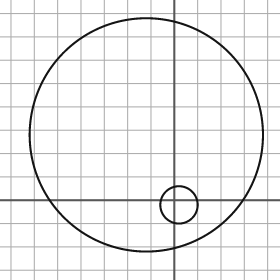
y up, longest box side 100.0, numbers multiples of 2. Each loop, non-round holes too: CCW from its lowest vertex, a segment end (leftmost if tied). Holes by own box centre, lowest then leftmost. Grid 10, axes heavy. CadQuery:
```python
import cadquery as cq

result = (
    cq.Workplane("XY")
    .moveTo(-12.0, 28.0)
    .circle(50.0)
    .moveTo(2.0, -2.0)
    .circle(8.0)
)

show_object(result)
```